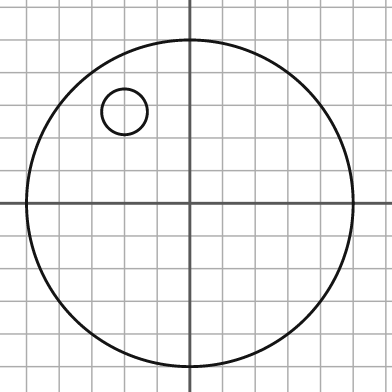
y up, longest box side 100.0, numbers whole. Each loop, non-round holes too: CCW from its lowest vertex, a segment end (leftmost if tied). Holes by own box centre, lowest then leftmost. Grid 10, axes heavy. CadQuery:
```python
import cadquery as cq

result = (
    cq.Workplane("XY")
    .moveTo(0.0, 0.0)
    .circle(50.0)
    .moveTo(-20.0, 28.0)
    .circle(7.0)
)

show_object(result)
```